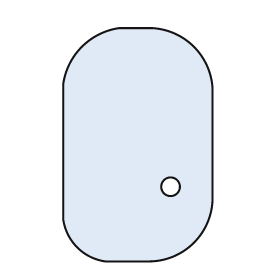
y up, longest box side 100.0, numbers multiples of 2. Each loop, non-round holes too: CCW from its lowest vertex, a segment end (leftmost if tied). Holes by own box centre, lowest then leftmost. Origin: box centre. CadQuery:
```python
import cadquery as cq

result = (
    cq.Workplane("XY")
    .moveTo(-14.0, -50.0)
    .lineTo(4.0, -50.0)
    .threePointArc((24.0, -42.0), (32.0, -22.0))
    .lineTo(32.0, 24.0)
    .threePointArc((24.0, 42.0), (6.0, 50.0))
    .lineTo(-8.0, 50.0)
    .threePointArc((-24.0, 42.0), (-32.0, 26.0))
    .lineTo(-32.0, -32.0)
    .threePointArc((-26.0, -44.0), (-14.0, -50.0))
    .close()
    .moveTo(14.0, -18.0)
    .circle(4.0)
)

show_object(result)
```